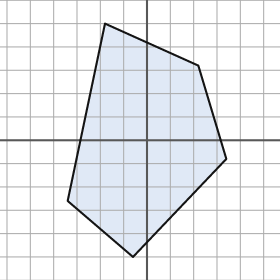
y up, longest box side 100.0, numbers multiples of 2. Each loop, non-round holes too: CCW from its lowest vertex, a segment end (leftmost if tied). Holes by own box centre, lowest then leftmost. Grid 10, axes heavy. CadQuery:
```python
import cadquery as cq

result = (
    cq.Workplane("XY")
    .moveTo(-6.0, -50.0)
    .lineTo(34.0, -8.0)
    .lineTo(22.0, 32.0)
    .lineTo(-18.0, 50.0)
    .lineTo(-34.0, -26.0)
    .close()
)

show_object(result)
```